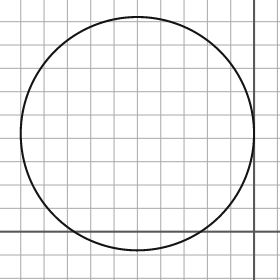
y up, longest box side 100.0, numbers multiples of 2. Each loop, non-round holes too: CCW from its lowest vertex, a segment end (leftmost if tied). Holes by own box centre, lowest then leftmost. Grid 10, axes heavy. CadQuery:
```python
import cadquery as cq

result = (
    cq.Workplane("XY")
    .moveTo(-50.0, 42.0)
    .circle(50.0)
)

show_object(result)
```